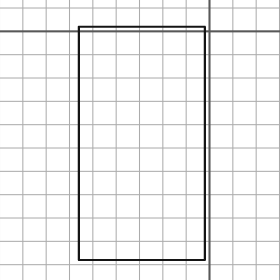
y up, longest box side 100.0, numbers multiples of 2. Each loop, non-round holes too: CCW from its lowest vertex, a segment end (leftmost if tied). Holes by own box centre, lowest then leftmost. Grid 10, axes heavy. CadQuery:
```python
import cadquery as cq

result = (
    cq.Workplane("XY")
    .moveTo(-56.0, -98.0)
    .lineTo(-2.0, -98.0)
    .lineTo(-2.0, 2.0)
    .lineTo(-56.0, 2.0)
    .close()
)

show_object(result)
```